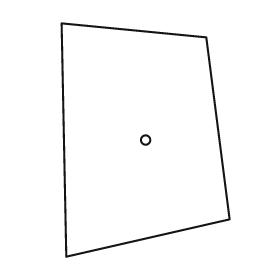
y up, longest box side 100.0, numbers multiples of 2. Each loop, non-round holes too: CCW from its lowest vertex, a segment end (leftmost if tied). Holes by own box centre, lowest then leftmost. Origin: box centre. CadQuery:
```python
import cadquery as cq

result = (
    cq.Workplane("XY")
    .moveTo(-34.0, -50.0)
    .lineTo(36.0, -34.0)
    .lineTo(26.0, 44.0)
    .lineTo(-36.0, 50.0)
    .close()
    .moveTo(0.0, 0.0)
    .circle(2.0)
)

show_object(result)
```